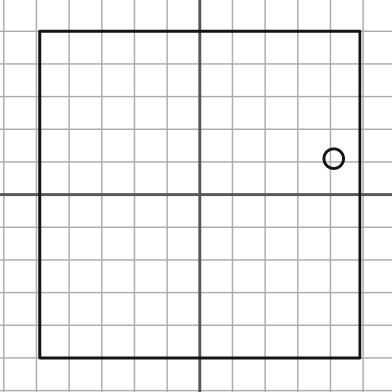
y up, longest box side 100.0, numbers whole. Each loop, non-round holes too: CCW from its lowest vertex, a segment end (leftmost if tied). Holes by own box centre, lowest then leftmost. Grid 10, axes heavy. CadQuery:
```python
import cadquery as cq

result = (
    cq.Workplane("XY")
    .moveTo(-49.0, -50.0)
    .lineTo(49.0, -50.0)
    .lineTo(49.0, 50.0)
    .lineTo(-49.0, 50.0)
    .close()
    .moveTo(41.0, 11.0)
    .circle(3.0)
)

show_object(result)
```